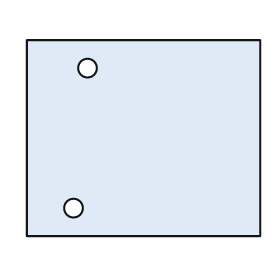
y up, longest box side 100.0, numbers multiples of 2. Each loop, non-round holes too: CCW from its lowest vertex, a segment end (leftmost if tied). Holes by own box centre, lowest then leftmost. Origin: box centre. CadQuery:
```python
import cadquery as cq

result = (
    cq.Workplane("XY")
    .moveTo(-50.0, -42.0)
    .lineTo(50.0, -42.0)
    .lineTo(50.0, 42.0)
    .lineTo(-50.0, 42.0)
    .close()
    .moveTo(-30.0, -30.0)
    .circle(4.0)
    .moveTo(-24.0, 30.0)
    .circle(4.0)
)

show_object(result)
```